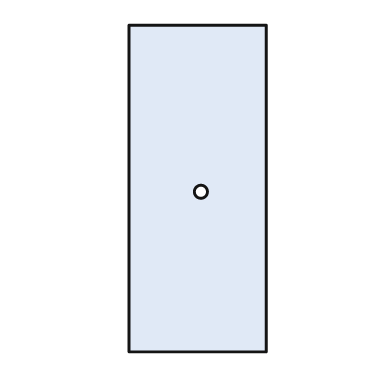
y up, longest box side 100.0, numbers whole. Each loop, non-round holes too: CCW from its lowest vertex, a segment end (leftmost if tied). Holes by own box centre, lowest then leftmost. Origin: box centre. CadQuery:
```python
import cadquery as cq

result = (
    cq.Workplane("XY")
    .moveTo(-21.0, -50.0)
    .lineTo(21.0, -50.0)
    .lineTo(21.0, 50.0)
    .lineTo(-21.0, 50.0)
    .close()
    .moveTo(1.0, -1.0)
    .circle(2.0)
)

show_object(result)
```